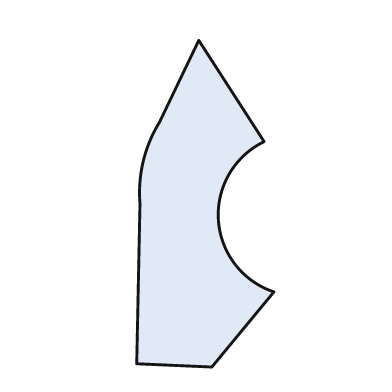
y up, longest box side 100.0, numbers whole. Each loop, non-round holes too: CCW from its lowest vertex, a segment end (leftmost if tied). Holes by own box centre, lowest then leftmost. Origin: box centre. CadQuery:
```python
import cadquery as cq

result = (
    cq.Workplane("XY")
    .moveTo(2.0, -50.0)
    .lineTo(21.0, -27.0)
    .threePointArc((4.0, -5.0), (18.0, 19.0))
    .lineTo(-2.0, 50.0)
    .lineTo(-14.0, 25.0)
    .threePointArc((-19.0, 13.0), (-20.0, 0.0))
    .lineTo(-21.0, -49.0)
    .close()
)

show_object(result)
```